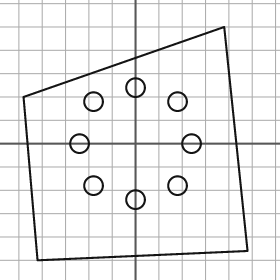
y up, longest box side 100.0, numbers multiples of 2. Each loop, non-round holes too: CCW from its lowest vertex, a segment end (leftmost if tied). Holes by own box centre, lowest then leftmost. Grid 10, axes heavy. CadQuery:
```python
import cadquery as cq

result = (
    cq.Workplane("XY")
    .moveTo(-42.0, -50.0)
    .lineTo(48.0, -46.0)
    .lineTo(38.0, 50.0)
    .lineTo(-48.0, 20.0)
    .close()
    .moveTo(0.0, -24.0)
    .circle(4.0)
    .moveTo(-18.0, -18.0)
    .circle(4.0)
    .moveTo(18.0, -18.0)
    .circle(4.0)
    .moveTo(-24.0, 0.0)
    .circle(4.0)
    .moveTo(24.0, 0.0)
    .circle(4.0)
    .moveTo(-18.0, 18.0)
    .circle(4.0)
    .moveTo(18.0, 18.0)
    .circle(4.0)
    .moveTo(0.0, 24.0)
    .circle(4.0)
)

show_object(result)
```